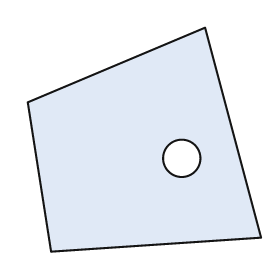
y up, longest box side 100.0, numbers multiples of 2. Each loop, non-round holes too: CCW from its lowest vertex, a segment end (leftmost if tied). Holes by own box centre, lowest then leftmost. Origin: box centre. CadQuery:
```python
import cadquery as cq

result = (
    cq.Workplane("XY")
    .moveTo(-40.0, -48.0)
    .lineTo(50.0, -42.0)
    .lineTo(26.0, 48.0)
    .lineTo(-50.0, 16.0)
    .close()
    .moveTo(16.0, -8.0)
    .circle(8.0)
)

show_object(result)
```